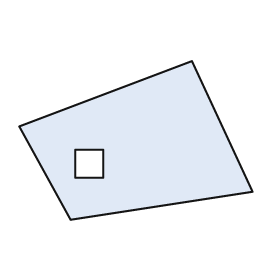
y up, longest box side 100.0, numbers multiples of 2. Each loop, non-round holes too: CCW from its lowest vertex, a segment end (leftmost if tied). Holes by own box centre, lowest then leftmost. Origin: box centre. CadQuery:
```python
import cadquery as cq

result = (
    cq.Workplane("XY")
    .moveTo(-28.0, -34.0)
    .lineTo(50.0, -22.0)
    .lineTo(24.0, 34.0)
    .lineTo(-50.0, 6.0)
    .close()
    .moveTo(-26.0, -16.0)
    .lineTo(-14.0, -16.0)
    .lineTo(-14.0, -4.0)
    .lineTo(-26.0, -4.0)
    .close()
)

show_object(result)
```